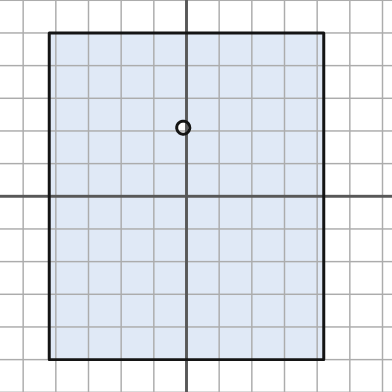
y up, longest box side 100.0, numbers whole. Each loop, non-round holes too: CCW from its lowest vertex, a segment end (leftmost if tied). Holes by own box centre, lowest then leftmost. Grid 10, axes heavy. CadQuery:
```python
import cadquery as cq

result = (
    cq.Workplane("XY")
    .moveTo(-42.0, -50.0)
    .lineTo(42.0, -50.0)
    .lineTo(42.0, 50.0)
    .lineTo(-42.0, 50.0)
    .close()
    .moveTo(-1.0, 21.0)
    .circle(2.0)
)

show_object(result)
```